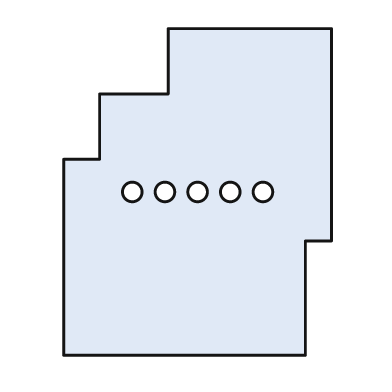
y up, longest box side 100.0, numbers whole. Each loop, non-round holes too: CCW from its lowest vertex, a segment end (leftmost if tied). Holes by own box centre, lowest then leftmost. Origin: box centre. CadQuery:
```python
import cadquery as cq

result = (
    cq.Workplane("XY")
    .moveTo(-41.0, -50.0)
    .lineTo(33.0, -50.0)
    .lineTo(33.0, -15.0)
    .lineTo(41.0, -15.0)
    .lineTo(41.0, 50.0)
    .lineTo(-9.0, 50.0)
    .lineTo(-9.0, 30.0)
    .lineTo(-30.0, 30.0)
    .lineTo(-30.0, 10.0)
    .lineTo(-41.0, 10.0)
    .close()
    .moveTo(-20.0, 0.0)
    .circle(3.0)
    .moveTo(-10.0, 0.0)
    .circle(3.0)
    .moveTo(0.0, 0.0)
    .circle(3.0)
    .moveTo(10.0, 0.0)
    .circle(3.0)
    .moveTo(20.0, 0.0)
    .circle(3.0)
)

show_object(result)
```